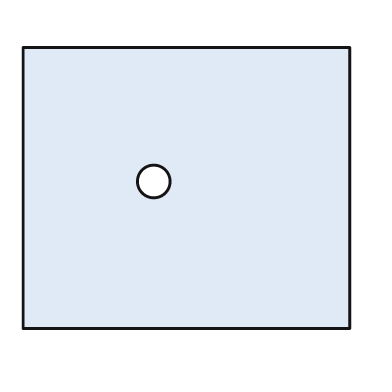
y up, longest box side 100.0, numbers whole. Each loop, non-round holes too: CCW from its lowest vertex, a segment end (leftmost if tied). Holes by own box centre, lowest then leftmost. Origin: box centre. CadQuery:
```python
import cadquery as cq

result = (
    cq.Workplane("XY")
    .moveTo(-50.0, -43.0)
    .lineTo(50.0, -43.0)
    .lineTo(50.0, 43.0)
    .lineTo(-50.0, 43.0)
    .close()
    .moveTo(-10.0, 2.0)
    .circle(5.0)
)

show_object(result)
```